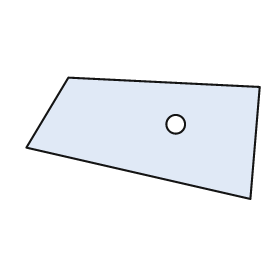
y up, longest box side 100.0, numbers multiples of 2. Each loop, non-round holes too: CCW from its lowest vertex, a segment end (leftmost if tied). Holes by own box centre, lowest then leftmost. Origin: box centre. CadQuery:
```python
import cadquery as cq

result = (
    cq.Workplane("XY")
    .moveTo(46.0, -26.0)
    .lineTo(50.0, 22.0)
    .lineTo(-32.0, 26.0)
    .lineTo(-50.0, -4.0)
    .close()
    .moveTo(14.0, 6.0)
    .circle(4.0)
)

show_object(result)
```